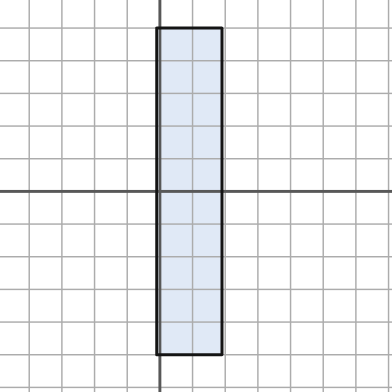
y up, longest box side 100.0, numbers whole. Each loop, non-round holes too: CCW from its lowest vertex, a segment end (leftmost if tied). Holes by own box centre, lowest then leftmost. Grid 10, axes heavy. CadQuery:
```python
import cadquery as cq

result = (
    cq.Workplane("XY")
    .moveTo(-1.0, -50.0)
    .lineTo(19.0, -50.0)
    .lineTo(19.0, 50.0)
    .lineTo(-1.0, 50.0)
    .close()
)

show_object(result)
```